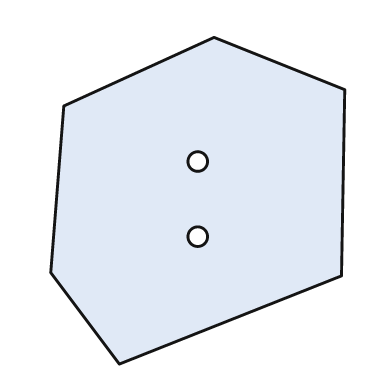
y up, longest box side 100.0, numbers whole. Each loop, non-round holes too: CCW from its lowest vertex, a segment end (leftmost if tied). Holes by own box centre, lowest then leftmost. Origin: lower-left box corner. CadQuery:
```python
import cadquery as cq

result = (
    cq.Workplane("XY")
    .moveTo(21.0, 0.0)
    .lineTo(89.0, 27.0)
    .lineTo(90.0, 84.0)
    .lineTo(50.0, 100.0)
    .lineTo(4.0, 79.0)
    .lineTo(0.0, 28.0)
    .close()
    .moveTo(45.0, 39.0)
    .circle(3.0)
    .moveTo(45.0, 62.0)
    .circle(3.0)
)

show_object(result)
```